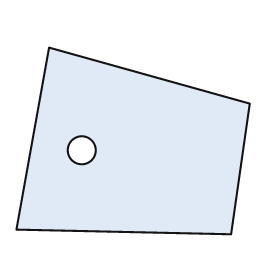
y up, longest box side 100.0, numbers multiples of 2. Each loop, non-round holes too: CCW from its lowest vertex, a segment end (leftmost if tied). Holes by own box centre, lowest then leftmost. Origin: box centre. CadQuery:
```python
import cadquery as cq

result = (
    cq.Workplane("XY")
    .moveTo(42.0, -40.0)
    .lineTo(50.0, 16.0)
    .lineTo(-36.0, 40.0)
    .lineTo(-50.0, -38.0)
    .close()
    .moveTo(-22.0, -4.0)
    .circle(6.0)
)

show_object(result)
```